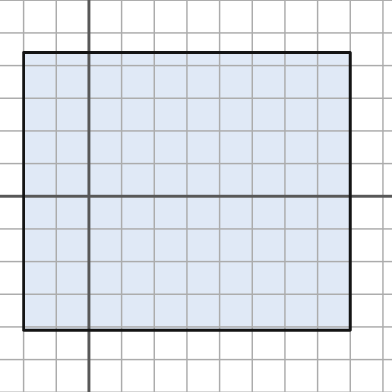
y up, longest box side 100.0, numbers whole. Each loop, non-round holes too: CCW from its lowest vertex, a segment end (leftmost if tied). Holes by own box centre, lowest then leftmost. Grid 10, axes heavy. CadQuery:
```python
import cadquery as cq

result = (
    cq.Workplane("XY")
    .moveTo(-20.0, -41.0)
    .lineTo(80.0, -41.0)
    .lineTo(80.0, 44.0)
    .lineTo(-20.0, 44.0)
    .close()
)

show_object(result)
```